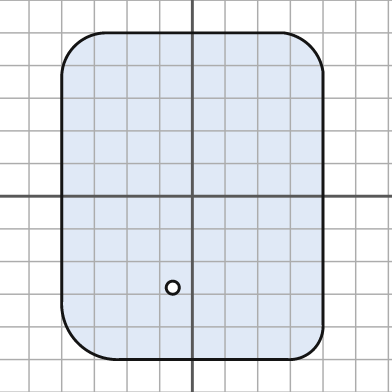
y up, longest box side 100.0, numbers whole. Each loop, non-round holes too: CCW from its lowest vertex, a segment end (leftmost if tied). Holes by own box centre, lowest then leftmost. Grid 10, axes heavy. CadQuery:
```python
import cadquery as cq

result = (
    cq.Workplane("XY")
    .moveTo(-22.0, -50.0)
    .lineTo(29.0, -50.0)
    .threePointArc((37.0, -47.0), (40.0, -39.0))
    .lineTo(40.0, 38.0)
    .threePointArc((36.0, 46.0), (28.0, 50.0))
    .lineTo(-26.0, 50.0)
    .threePointArc((-36.0, 46.0), (-40.0, 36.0))
    .lineTo(-40.0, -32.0)
    .threePointArc((-35.0, -45.0), (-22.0, -50.0))
    .close()
    .moveTo(-6.0, -28.0)
    .circle(2.0)
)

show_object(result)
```